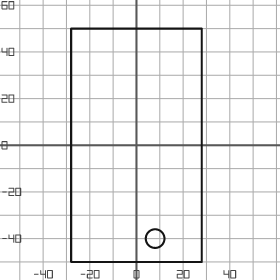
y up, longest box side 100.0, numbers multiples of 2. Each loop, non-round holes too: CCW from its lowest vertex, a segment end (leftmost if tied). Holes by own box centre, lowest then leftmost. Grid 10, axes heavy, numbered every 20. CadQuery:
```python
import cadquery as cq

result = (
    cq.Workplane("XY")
    .moveTo(-28.0, -50.0)
    .lineTo(28.0, -50.0)
    .lineTo(28.0, 50.0)
    .lineTo(-28.0, 50.0)
    .close()
    .moveTo(8.0, -40.0)
    .circle(4.0)
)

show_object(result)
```